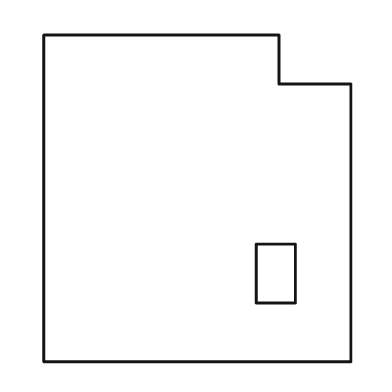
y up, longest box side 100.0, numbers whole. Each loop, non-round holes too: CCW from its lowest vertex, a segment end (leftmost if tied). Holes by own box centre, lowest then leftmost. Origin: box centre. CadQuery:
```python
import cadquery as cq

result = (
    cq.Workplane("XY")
    .moveTo(-47.0, -50.0)
    .lineTo(47.0, -50.0)
    .lineTo(47.0, 35.0)
    .lineTo(25.0, 35.0)
    .lineTo(25.0, 50.0)
    .lineTo(-47.0, 50.0)
    .close()
    .moveTo(18.0, -32.0)
    .lineTo(30.0, -32.0)
    .lineTo(30.0, -14.0)
    .lineTo(18.0, -14.0)
    .close()
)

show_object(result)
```